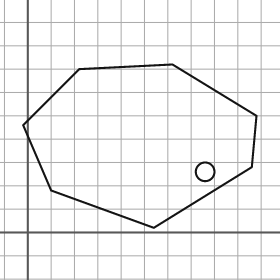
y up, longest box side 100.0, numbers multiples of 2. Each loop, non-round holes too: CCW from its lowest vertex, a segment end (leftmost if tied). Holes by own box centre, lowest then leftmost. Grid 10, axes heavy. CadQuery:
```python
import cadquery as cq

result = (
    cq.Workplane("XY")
    .moveTo(54.0, 2.0)
    .lineTo(96.0, 28.0)
    .lineTo(98.0, 50.0)
    .lineTo(62.0, 72.0)
    .lineTo(22.0, 70.0)
    .lineTo(-2.0, 46.0)
    .lineTo(10.0, 18.0)
    .close()
    .moveTo(76.0, 26.0)
    .circle(4.0)
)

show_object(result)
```